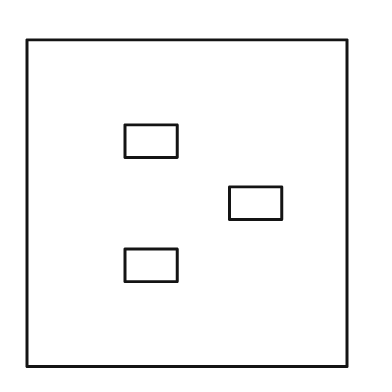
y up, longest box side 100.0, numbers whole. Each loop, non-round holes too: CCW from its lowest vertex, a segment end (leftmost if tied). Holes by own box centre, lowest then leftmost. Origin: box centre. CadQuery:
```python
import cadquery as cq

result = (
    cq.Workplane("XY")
    .moveTo(-49.0, -50.0)
    .lineTo(49.0, -50.0)
    .lineTo(49.0, 50.0)
    .lineTo(-49.0, 50.0)
    .close()
    .moveTo(-19.0, -24.0)
    .lineTo(-3.0, -24.0)
    .lineTo(-3.0, -14.0)
    .lineTo(-19.0, -14.0)
    .close()
    .moveTo(13.0, -5.0)
    .lineTo(29.0, -5.0)
    .lineTo(29.0, 5.0)
    .lineTo(13.0, 5.0)
    .close()
    .moveTo(-19.0, 14.0)
    .lineTo(-3.0, 14.0)
    .lineTo(-3.0, 24.0)
    .lineTo(-19.0, 24.0)
    .close()
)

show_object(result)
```